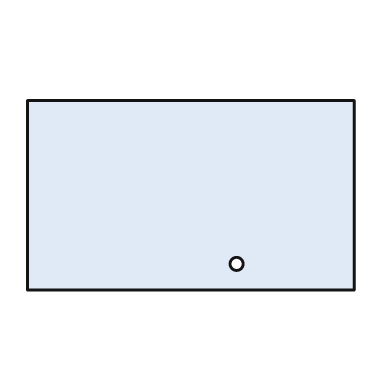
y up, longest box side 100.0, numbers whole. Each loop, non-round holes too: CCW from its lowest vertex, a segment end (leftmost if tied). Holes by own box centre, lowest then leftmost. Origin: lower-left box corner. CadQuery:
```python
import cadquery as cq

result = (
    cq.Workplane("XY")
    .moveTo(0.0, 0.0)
    .lineTo(100.0, 0.0)
    .lineTo(100.0, 58.0)
    .lineTo(0.0, 58.0)
    .close()
    .moveTo(64.0, 8.0)
    .circle(2.0)
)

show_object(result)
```